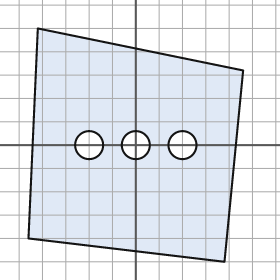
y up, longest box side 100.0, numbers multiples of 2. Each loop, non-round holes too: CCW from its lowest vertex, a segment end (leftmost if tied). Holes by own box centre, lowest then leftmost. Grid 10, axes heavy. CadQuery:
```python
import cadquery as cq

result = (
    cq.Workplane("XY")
    .moveTo(38.0, -50.0)
    .lineTo(46.0, 32.0)
    .lineTo(-42.0, 50.0)
    .lineTo(-46.0, -40.0)
    .close()
    .moveTo(-20.0, 0.0)
    .circle(6.0)
    .moveTo(0.0, 0.0)
    .circle(6.0)
    .moveTo(20.0, 0.0)
    .circle(6.0)
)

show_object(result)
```